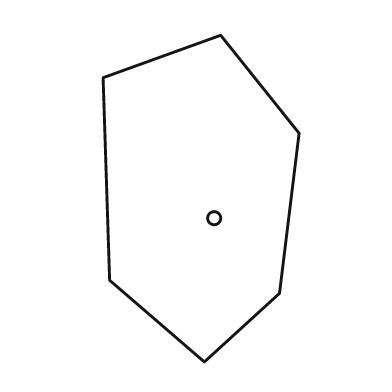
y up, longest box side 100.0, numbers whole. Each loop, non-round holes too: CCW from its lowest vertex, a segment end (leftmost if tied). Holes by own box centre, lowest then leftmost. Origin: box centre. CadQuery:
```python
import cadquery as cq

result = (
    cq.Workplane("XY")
    .moveTo(1.0, -50.0)
    .lineTo(24.0, -29.0)
    .lineTo(30.0, 20.0)
    .lineTo(6.0, 50.0)
    .lineTo(-30.0, 37.0)
    .lineTo(-28.0, -25.0)
    .close()
    .moveTo(4.0, -6.0)
    .circle(2.0)
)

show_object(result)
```